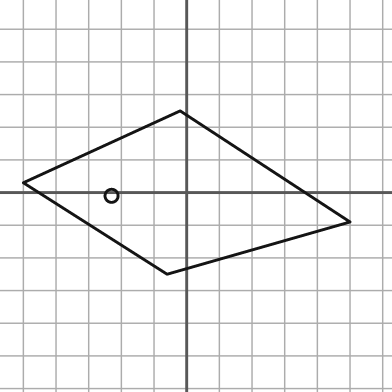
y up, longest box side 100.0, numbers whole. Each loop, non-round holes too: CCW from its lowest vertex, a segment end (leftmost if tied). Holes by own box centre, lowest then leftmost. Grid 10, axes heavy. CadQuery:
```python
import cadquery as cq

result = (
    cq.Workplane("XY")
    .moveTo(-6.0, -25.0)
    .lineTo(50.0, -9.0)
    .lineTo(-2.0, 25.0)
    .lineTo(-50.0, 3.0)
    .close()
    .moveTo(-23.0, -1.0)
    .circle(2.0)
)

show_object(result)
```